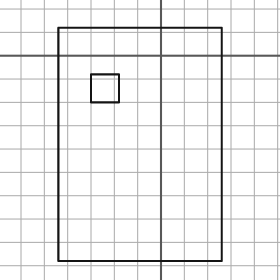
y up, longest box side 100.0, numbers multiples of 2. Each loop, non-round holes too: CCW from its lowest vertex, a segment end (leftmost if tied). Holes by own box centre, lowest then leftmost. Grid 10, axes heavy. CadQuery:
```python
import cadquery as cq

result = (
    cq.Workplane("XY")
    .moveTo(-44.0, -88.0)
    .lineTo(26.0, -88.0)
    .lineTo(26.0, 12.0)
    .lineTo(-44.0, 12.0)
    .close()
    .moveTo(-30.0, -20.0)
    .lineTo(-18.0, -20.0)
    .lineTo(-18.0, -8.0)
    .lineTo(-30.0, -8.0)
    .close()
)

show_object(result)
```